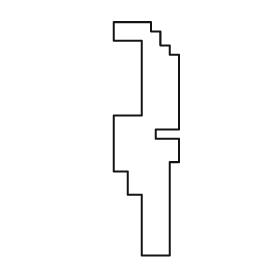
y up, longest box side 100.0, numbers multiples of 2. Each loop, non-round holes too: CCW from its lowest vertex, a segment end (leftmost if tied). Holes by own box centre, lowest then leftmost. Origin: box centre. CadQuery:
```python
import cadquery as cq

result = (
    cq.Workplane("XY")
    .moveTo(-2.0, -50.0)
    .lineTo(10.0, -50.0)
    .lineTo(10.0, -10.0)
    .lineTo(14.0, -10.0)
    .lineTo(14.0, 0.0)
    .lineTo(4.0, 0.0)
    .lineTo(4.0, 4.0)
    .lineTo(14.0, 4.0)
    .lineTo(14.0, 36.0)
    .lineTo(10.0, 36.0)
    .lineTo(10.0, 40.0)
    .lineTo(6.0, 40.0)
    .lineTo(6.0, 46.0)
    .lineTo(2.0, 46.0)
    .lineTo(2.0, 50.0)
    .lineTo(-14.0, 50.0)
    .lineTo(-14.0, 42.0)
    .lineTo(-2.0, 42.0)
    .lineTo(-2.0, 10.0)
    .lineTo(-14.0, 10.0)
    .lineTo(-14.0, -14.0)
    .lineTo(-8.0, -14.0)
    .lineTo(-8.0, -24.0)
    .lineTo(-2.0, -24.0)
    .close()
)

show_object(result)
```